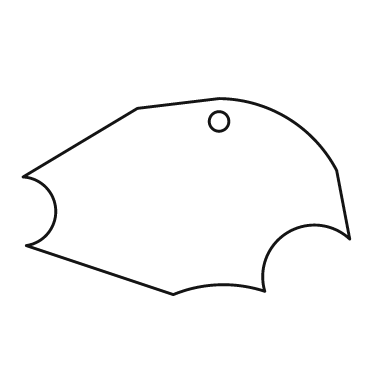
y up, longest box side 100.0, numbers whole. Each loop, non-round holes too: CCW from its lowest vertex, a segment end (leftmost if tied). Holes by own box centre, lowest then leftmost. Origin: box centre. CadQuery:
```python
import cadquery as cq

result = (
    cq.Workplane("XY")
    .moveTo(-4.0, -30.0)
    .threePointArc((10.0, -27.0), (24.0, -29.0))
    .threePointArc((31.0, -11.0), (50.0, -13.0))
    .lineTo(46.0, 8.0)
    .threePointArc((31.0, 24.0), (10.0, 30.0))
    .lineTo(-15.0, 27.0)
    .lineTo(-50.0, 6.0)
    .threePointArc((-40.0, -4.0), (-49.0, -15.0))
    .close()
    .moveTo(10.0, 23.0)
    .circle(3.0)
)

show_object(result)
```